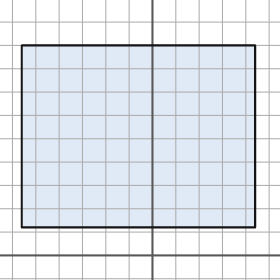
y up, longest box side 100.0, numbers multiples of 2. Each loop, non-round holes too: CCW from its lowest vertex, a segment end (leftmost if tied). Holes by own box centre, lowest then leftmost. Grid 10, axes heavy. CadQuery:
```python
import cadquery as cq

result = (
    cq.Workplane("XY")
    .moveTo(-56.0, 12.0)
    .lineTo(44.0, 12.0)
    .lineTo(44.0, 90.0)
    .lineTo(-56.0, 90.0)
    .close()
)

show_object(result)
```